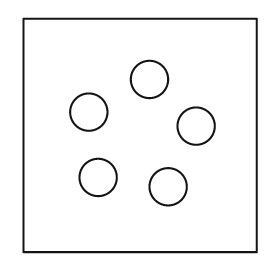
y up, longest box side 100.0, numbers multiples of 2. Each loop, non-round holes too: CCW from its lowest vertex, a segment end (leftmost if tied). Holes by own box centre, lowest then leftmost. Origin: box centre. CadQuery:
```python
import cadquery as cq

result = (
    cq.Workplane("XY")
    .moveTo(-50.0, -50.0)
    .lineTo(50.0, -50.0)
    .lineTo(50.0, 50.0)
    .lineTo(-50.0, 50.0)
    .close()
    .moveTo(12.0, -22.0)
    .circle(8.0)
    .moveTo(-18.0, -18.0)
    .circle(8.0)
    .moveTo(24.0, 4.0)
    .circle(8.0)
    .moveTo(-22.0, 10.0)
    .circle(8.0)
    .moveTo(4.0, 24.0)
    .circle(8.0)
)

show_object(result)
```